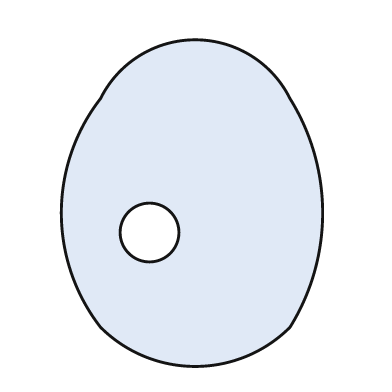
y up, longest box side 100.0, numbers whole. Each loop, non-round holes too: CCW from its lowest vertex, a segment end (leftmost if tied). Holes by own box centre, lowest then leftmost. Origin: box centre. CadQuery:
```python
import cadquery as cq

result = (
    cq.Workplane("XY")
    .moveTo(-28.0, -38.0)
    .threePointArc((1.0, -50.0), (30.0, -38.0))
    .threePointArc((40.0, -3.0), (30.0, 32.0))
    .threePointArc((1.0, 50.0), (-28.0, 32.0))
    .threePointArc((-40.0, -3.0), (-28.0, -38.0))
    .close()
    .moveTo(-13.0, -9.0)
    .circle(9.0)
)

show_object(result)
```